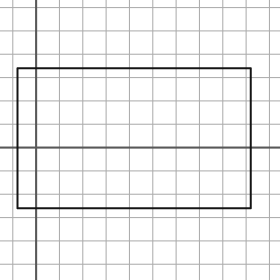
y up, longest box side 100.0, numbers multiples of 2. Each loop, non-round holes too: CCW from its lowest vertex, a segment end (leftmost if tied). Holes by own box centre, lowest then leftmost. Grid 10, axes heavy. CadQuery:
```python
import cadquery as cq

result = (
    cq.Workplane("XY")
    .moveTo(-8.0, -26.0)
    .lineTo(92.0, -26.0)
    .lineTo(92.0, 34.0)
    .lineTo(-8.0, 34.0)
    .close()
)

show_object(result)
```